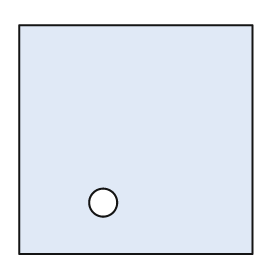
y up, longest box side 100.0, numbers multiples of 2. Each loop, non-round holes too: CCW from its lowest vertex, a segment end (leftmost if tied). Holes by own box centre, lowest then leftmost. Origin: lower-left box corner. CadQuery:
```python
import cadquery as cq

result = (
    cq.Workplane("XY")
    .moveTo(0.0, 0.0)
    .lineTo(100.0, 0.0)
    .lineTo(100.0, 98.0)
    .lineTo(0.0, 98.0)
    .close()
    .moveTo(36.0, 22.0)
    .circle(6.0)
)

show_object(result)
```